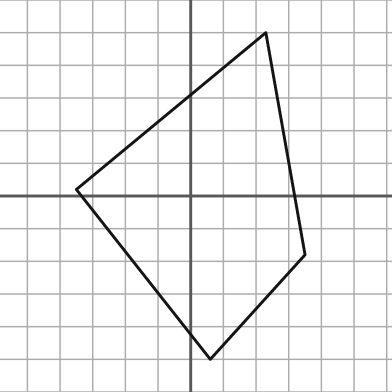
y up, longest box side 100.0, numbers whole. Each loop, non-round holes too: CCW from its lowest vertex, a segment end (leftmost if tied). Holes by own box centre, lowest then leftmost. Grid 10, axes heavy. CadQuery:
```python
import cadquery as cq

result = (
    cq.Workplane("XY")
    .moveTo(6.0, -50.0)
    .lineTo(35.0, -18.0)
    .lineTo(23.0, 50.0)
    .lineTo(-35.0, 2.0)
    .close()
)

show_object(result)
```